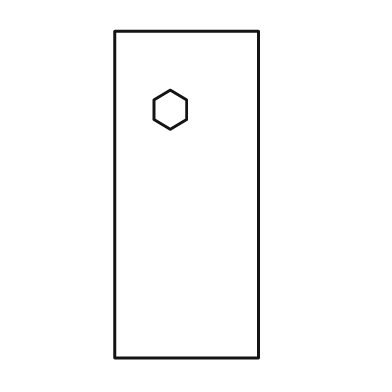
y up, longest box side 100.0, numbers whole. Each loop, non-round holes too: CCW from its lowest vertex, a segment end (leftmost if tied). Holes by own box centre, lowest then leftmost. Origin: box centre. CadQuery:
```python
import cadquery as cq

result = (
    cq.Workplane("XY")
    .moveTo(-22.0, -50.0)
    .lineTo(22.0, -50.0)
    .lineTo(22.0, 50.0)
    .lineTo(-22.0, 50.0)
    .close()
    .moveTo(-5.0, 20.0)
    .lineTo(0.0, 23.0)
    .lineTo(0.0, 29.0)
    .lineTo(-5.0, 32.0)
    .lineTo(-10.0, 29.0)
    .lineTo(-10.0, 23.0)
    .close()
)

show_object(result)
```